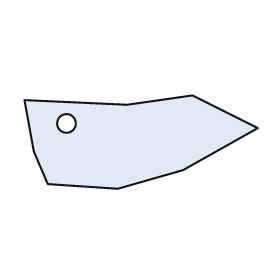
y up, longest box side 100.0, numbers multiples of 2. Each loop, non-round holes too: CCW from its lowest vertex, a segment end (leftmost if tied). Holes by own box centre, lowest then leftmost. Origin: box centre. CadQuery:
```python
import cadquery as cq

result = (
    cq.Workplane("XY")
    .moveTo(-10.0, -20.0)
    .lineTo(18.0, -12.0)
    .lineTo(50.0, 6.0)
    .lineTo(22.0, 20.0)
    .lineTo(-6.0, 16.0)
    .lineTo(-50.0, 18.0)
    .lineTo(-46.0, -4.0)
    .lineTo(-40.0, -18.0)
    .close()
    .moveTo(-32.0, 8.0)
    .circle(4.0)
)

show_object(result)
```